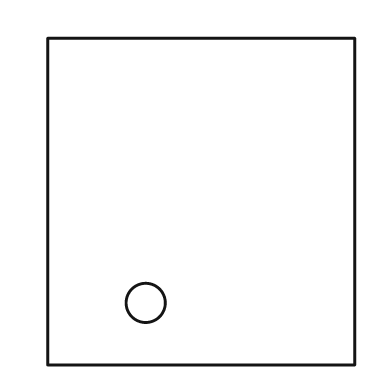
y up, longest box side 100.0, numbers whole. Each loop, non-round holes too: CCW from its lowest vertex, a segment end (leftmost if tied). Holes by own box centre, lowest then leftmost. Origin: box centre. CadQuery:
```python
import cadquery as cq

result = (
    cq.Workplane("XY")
    .moveTo(-47.0, -50.0)
    .lineTo(47.0, -50.0)
    .lineTo(47.0, 50.0)
    .lineTo(-47.0, 50.0)
    .close()
    .moveTo(-17.0, -31.0)
    .circle(6.0)
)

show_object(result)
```